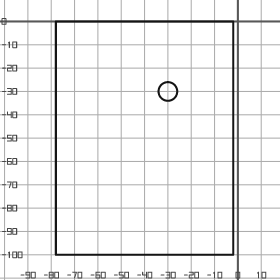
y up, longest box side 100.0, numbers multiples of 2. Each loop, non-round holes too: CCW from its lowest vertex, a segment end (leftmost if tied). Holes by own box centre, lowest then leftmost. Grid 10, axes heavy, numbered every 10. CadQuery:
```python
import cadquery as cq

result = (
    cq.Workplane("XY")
    .moveTo(-78.0, -100.0)
    .lineTo(-2.0, -100.0)
    .lineTo(-2.0, 0.0)
    .lineTo(-78.0, 0.0)
    .close()
    .moveTo(-30.0, -30.0)
    .circle(4.0)
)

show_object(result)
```